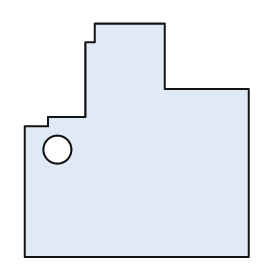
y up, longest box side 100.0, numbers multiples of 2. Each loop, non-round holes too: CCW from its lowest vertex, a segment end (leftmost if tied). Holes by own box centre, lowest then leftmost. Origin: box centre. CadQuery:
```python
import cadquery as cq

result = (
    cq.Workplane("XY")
    .moveTo(-48.0, -50.0)
    .lineTo(48.0, -50.0)
    .lineTo(48.0, 22.0)
    .lineTo(12.0, 22.0)
    .lineTo(12.0, 50.0)
    .lineTo(-18.0, 50.0)
    .lineTo(-18.0, 42.0)
    .lineTo(-22.0, 42.0)
    .lineTo(-22.0, 10.0)
    .lineTo(-38.0, 10.0)
    .lineTo(-38.0, 6.0)
    .lineTo(-48.0, 6.0)
    .close()
    .moveTo(-34.0, -4.0)
    .circle(6.0)
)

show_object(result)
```